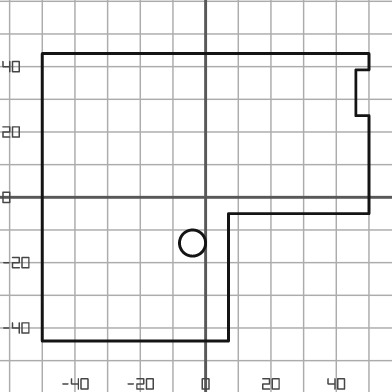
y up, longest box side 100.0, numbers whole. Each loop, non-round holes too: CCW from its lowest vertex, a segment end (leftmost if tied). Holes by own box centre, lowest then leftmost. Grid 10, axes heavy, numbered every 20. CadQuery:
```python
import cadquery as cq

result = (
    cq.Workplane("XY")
    .moveTo(-50.0, -44.0)
    .lineTo(7.0, -44.0)
    .lineTo(7.0, -5.0)
    .lineTo(50.0, -5.0)
    .lineTo(50.0, 25.0)
    .lineTo(46.0, 25.0)
    .lineTo(46.0, 39.0)
    .lineTo(50.0, 39.0)
    .lineTo(50.0, 44.0)
    .lineTo(-50.0, 44.0)
    .close()
    .moveTo(-4.0, -14.0)
    .circle(4.0)
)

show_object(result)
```